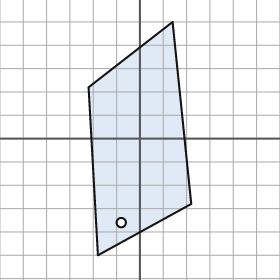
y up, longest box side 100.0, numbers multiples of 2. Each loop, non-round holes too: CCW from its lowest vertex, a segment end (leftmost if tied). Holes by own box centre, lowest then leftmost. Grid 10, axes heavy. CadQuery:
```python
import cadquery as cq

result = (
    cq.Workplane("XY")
    .moveTo(-18.0, -50.0)
    .lineTo(22.0, -28.0)
    .lineTo(14.0, 50.0)
    .lineTo(-22.0, 22.0)
    .close()
    .moveTo(-8.0, -36.0)
    .circle(2.0)
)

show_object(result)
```